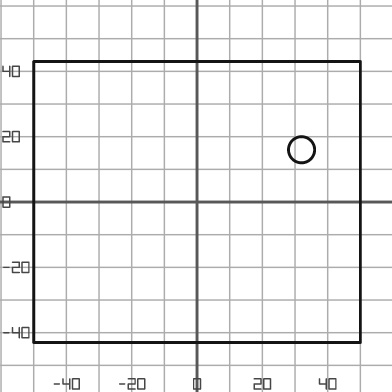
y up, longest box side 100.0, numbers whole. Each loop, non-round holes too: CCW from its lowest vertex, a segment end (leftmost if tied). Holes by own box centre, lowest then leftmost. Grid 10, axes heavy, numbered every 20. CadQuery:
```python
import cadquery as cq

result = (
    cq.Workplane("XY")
    .moveTo(-50.0, -43.0)
    .lineTo(50.0, -43.0)
    .lineTo(50.0, 43.0)
    .lineTo(-50.0, 43.0)
    .close()
    .moveTo(32.0, 16.0)
    .circle(4.0)
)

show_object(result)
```